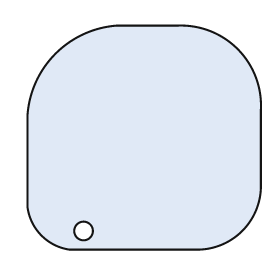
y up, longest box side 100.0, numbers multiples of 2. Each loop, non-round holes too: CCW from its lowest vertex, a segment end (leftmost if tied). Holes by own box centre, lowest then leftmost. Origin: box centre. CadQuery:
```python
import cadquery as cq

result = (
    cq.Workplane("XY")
    .moveTo(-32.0, -48.0)
    .lineTo(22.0, -48.0)
    .threePointArc((42.0, -40.0), (50.0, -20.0))
    .lineTo(50.0, 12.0)
    .threePointArc((40.0, 38.0), (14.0, 48.0))
    .lineTo(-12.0, 48.0)
    .threePointArc((-38.0, 36.0), (-50.0, 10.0))
    .lineTo(-50.0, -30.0)
    .threePointArc((-44.0, -42.0), (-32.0, -48.0))
    .close()
    .moveTo(-26.0, -40.0)
    .circle(4.0)
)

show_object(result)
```